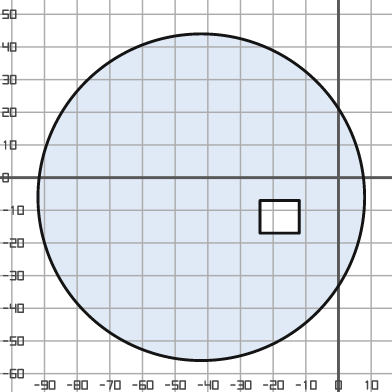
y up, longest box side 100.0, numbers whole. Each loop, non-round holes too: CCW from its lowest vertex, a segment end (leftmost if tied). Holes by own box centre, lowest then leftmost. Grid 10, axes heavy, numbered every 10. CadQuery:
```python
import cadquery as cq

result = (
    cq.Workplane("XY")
    .moveTo(-42.0, -6.0)
    .circle(50.0)
    .moveTo(-24.0, -17.0)
    .lineTo(-12.0, -17.0)
    .lineTo(-12.0, -7.0)
    .lineTo(-24.0, -7.0)
    .close()
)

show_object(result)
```